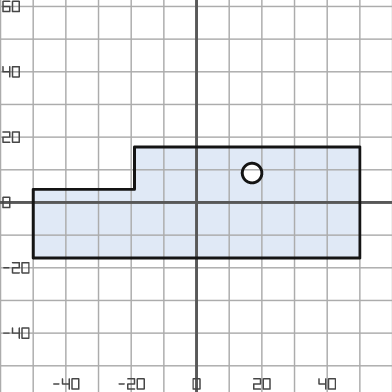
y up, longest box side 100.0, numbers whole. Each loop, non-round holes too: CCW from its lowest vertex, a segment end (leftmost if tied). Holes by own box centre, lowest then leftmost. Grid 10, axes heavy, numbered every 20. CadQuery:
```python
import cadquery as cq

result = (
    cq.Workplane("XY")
    .moveTo(-50.0, -17.0)
    .lineTo(50.0, -17.0)
    .lineTo(50.0, 17.0)
    .lineTo(-19.0, 17.0)
    .lineTo(-19.0, 4.0)
    .lineTo(-50.0, 4.0)
    .close()
    .moveTo(17.0, 9.0)
    .circle(3.0)
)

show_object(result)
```